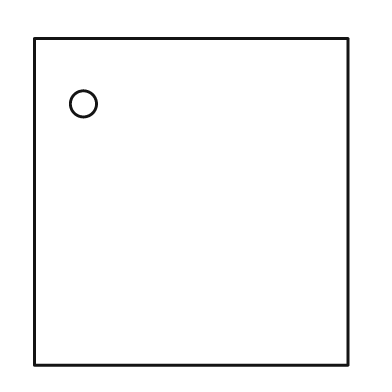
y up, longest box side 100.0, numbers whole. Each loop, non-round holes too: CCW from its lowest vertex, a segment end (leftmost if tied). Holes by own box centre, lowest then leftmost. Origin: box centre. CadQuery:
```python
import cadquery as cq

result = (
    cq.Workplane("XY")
    .moveTo(-48.0, -50.0)
    .lineTo(48.0, -50.0)
    .lineTo(48.0, 50.0)
    .lineTo(-48.0, 50.0)
    .close()
    .moveTo(-33.0, 30.0)
    .circle(4.0)
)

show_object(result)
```